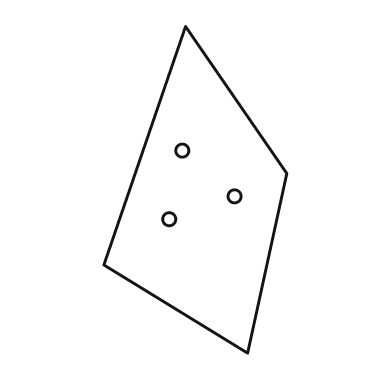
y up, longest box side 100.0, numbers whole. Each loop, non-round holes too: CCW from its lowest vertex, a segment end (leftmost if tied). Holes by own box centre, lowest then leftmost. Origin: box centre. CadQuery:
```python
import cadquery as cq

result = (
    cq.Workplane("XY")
    .moveTo(16.0, -50.0)
    .lineTo(28.0, 5.0)
    .lineTo(-3.0, 50.0)
    .lineTo(-28.0, -23.0)
    .close()
    .moveTo(-8.0, -9.0)
    .circle(2.0)
    .moveTo(12.0, -2.0)
    .circle(2.0)
    .moveTo(-4.0, 12.0)
    .circle(2.0)
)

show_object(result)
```